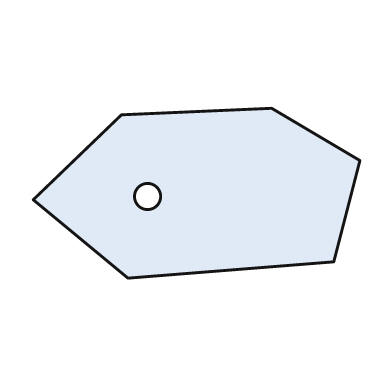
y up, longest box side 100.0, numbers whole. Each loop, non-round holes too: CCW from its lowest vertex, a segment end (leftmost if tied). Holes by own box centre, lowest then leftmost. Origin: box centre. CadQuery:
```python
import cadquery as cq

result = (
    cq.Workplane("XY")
    .moveTo(-21.0, -26.0)
    .lineTo(42.0, -21.0)
    .lineTo(50.0, 10.0)
    .lineTo(23.0, 26.0)
    .lineTo(-23.0, 24.0)
    .lineTo(-50.0, -2.0)
    .close()
    .moveTo(-15.0, -1.0)
    .circle(4.0)
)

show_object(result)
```